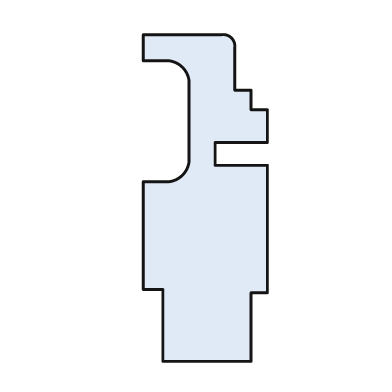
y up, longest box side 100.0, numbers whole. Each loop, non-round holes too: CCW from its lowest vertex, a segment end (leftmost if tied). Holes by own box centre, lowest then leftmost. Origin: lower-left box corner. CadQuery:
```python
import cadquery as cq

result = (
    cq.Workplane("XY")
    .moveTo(6.0, 0.0)
    .lineTo(33.0, 0.0)
    .lineTo(33.0, 21.0)
    .lineTo(38.0, 21.0)
    .lineTo(38.0, 60.0)
    .lineTo(22.0, 60.0)
    .lineTo(22.0, 67.0)
    .lineTo(38.0, 67.0)
    .lineTo(38.0, 77.0)
    .lineTo(33.0, 77.0)
    .lineTo(33.0, 83.0)
    .lineTo(28.0, 83.0)
    .lineTo(28.0, 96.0)
    .threePointArc((27.0, 99.0), (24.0, 100.0))
    .lineTo(0.0, 100.0)
    .lineTo(0.0, 92.0)
    .lineTo(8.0, 92.0)
    .threePointArc((12.0, 90.0), (14.0, 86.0))
    .lineTo(14.0, 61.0)
    .threePointArc((12.0, 57.0), (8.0, 55.0))
    .lineTo(0.0, 55.0)
    .lineTo(0.0, 22.0)
    .lineTo(6.0, 22.0)
    .close()
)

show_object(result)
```